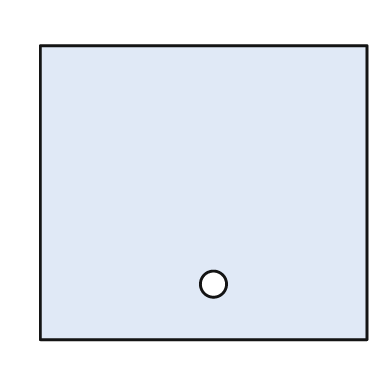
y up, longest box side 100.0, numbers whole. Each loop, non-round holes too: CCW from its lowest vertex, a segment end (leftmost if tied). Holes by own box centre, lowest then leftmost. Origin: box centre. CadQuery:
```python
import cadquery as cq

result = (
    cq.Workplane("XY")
    .moveTo(-50.0, -45.0)
    .lineTo(50.0, -45.0)
    .lineTo(50.0, 45.0)
    .lineTo(-50.0, 45.0)
    .close()
    .moveTo(3.0, -28.0)
    .circle(4.0)
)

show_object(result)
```